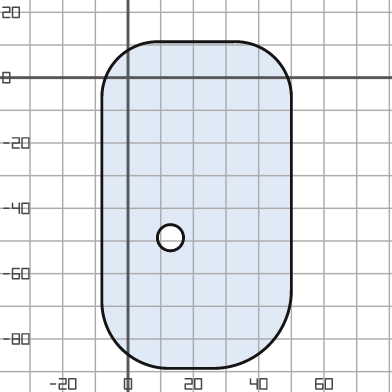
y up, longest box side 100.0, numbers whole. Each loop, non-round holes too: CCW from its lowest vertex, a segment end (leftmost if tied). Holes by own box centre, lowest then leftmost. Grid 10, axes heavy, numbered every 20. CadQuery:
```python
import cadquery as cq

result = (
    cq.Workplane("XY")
    .moveTo(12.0, -89.0)
    .lineTo(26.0, -89.0)
    .threePointArc((43.0, -82.0), (50.0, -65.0))
    .lineTo(50.0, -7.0)
    .threePointArc((45.0, 6.0), (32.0, 11.0))
    .lineTo(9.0, 11.0)
    .threePointArc((-3.0, 6.0), (-8.0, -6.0))
    .lineTo(-8.0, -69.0)
    .threePointArc((-2.0, -83.0), (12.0, -89.0))
    .close()
    .moveTo(13.0, -49.0)
    .circle(4.0)
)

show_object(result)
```